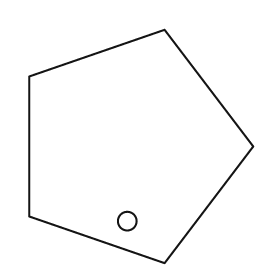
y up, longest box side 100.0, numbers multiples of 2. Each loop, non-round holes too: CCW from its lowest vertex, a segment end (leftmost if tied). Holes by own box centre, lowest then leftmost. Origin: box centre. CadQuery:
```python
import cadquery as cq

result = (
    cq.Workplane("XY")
    .moveTo(10.0, -50.0)
    .lineTo(48.0, 0.0)
    .lineTo(10.0, 50.0)
    .lineTo(-48.0, 30.0)
    .lineTo(-48.0, -30.0)
    .close()
    .moveTo(-6.0, -32.0)
    .circle(4.0)
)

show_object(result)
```